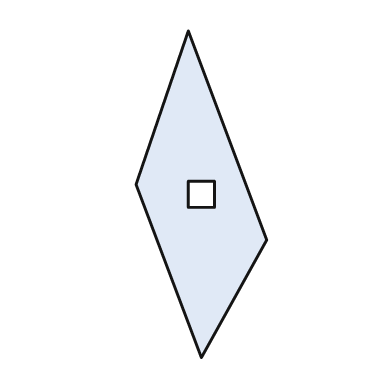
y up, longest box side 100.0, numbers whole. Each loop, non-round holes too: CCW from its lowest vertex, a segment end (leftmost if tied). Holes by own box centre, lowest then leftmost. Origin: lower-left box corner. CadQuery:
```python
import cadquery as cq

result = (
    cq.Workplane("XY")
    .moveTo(20.0, 0.0)
    .lineTo(40.0, 36.0)
    .lineTo(16.0, 100.0)
    .lineTo(0.0, 53.0)
    .close()
    .moveTo(16.0, 46.0)
    .lineTo(24.0, 46.0)
    .lineTo(24.0, 54.0)
    .lineTo(16.0, 54.0)
    .close()
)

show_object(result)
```